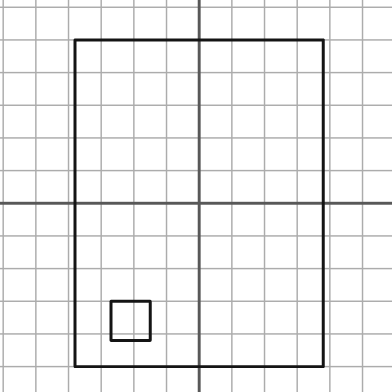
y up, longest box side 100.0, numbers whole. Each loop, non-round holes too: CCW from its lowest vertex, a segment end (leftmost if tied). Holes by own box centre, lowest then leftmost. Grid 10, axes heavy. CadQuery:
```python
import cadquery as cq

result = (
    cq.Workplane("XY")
    .moveTo(-38.0, -50.0)
    .lineTo(38.0, -50.0)
    .lineTo(38.0, 50.0)
    .lineTo(-38.0, 50.0)
    .close()
    .moveTo(-27.0, -42.0)
    .lineTo(-15.0, -42.0)
    .lineTo(-15.0, -30.0)
    .lineTo(-27.0, -30.0)
    .close()
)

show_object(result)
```